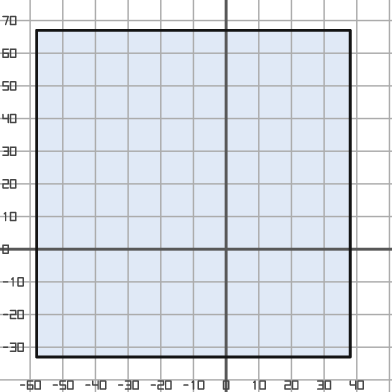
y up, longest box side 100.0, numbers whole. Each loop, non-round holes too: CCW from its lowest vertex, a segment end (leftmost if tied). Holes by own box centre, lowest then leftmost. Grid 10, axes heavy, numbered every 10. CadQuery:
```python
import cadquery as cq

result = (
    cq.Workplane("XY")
    .moveTo(-58.0, -33.0)
    .lineTo(38.0, -33.0)
    .lineTo(38.0, 67.0)
    .lineTo(-58.0, 67.0)
    .close()
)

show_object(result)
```